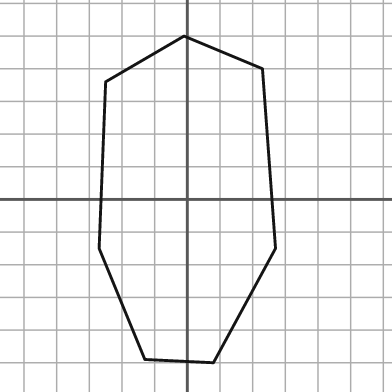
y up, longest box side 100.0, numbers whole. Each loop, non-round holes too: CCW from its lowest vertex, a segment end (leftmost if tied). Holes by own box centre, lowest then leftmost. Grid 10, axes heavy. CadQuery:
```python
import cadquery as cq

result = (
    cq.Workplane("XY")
    .moveTo(8.0, -50.0)
    .lineTo(27.0, -15.0)
    .lineTo(23.0, 40.0)
    .lineTo(-1.0, 50.0)
    .lineTo(-25.0, 36.0)
    .lineTo(-27.0, -15.0)
    .lineTo(-13.0, -49.0)
    .close()
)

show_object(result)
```